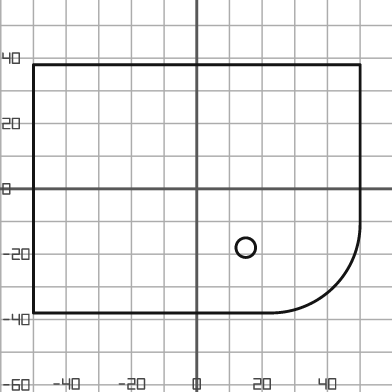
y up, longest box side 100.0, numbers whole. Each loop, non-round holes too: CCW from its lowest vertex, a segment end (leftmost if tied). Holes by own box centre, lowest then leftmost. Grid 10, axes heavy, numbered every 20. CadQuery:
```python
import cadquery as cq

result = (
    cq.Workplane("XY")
    .moveTo(-50.0, -38.0)
    .lineTo(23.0, -38.0)
    .threePointArc((42.0, -30.0), (50.0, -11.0))
    .lineTo(50.0, 38.0)
    .lineTo(-50.0, 38.0)
    .close()
    .moveTo(15.0, -18.0)
    .circle(3.0)
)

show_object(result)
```